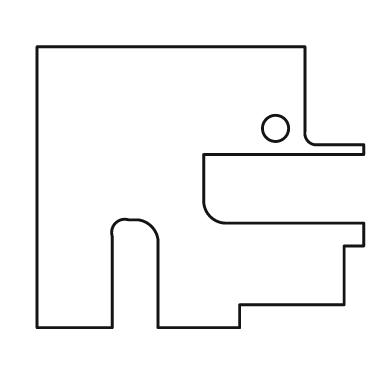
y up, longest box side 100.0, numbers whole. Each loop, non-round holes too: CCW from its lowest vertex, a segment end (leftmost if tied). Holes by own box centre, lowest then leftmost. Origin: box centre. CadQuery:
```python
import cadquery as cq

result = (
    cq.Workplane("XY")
    .moveTo(-50.0, -43.0)
    .lineTo(-27.0, -43.0)
    .lineTo(-27.0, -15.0)
    .threePointArc((-26.0, -11.0), (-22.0, -10.0))
    .lineTo(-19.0, -10.0)
    .threePointArc((-15.0, -12.0), (-13.0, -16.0))
    .lineTo(-13.0, -43.0)
    .lineTo(12.0, -43.0)
    .lineTo(12.0, -36.0)
    .lineTo(44.0, -36.0)
    .lineTo(44.0, -18.0)
    .lineTo(50.0, -18.0)
    .lineTo(50.0, -11.0)
    .lineTo(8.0, -11.0)
    .threePointArc((3.0, -9.0), (1.0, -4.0))
    .lineTo(1.0, 10.0)
    .lineTo(50.0, 10.0)
    .lineTo(50.0, 13.0)
    .lineTo(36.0, 13.0)
    .threePointArc((33.0, 14.0), (32.0, 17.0))
    .lineTo(32.0, 43.0)
    .lineTo(-50.0, 43.0)
    .close()
    .moveTo(23.0, 18.0)
    .circle(4.0)
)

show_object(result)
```